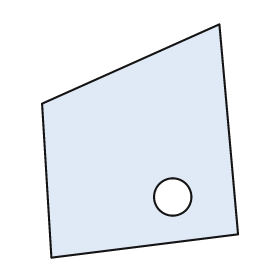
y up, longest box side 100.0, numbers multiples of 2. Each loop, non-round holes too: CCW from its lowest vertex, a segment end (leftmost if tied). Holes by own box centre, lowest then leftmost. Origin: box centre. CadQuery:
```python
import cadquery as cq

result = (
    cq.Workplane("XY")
    .moveTo(-38.0, -50.0)
    .lineTo(42.0, -40.0)
    .lineTo(34.0, 50.0)
    .lineTo(-42.0, 16.0)
    .close()
    .moveTo(14.0, -24.0)
    .circle(8.0)
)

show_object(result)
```